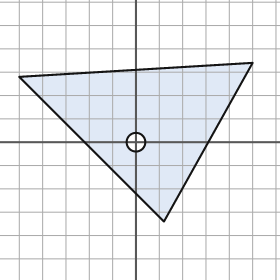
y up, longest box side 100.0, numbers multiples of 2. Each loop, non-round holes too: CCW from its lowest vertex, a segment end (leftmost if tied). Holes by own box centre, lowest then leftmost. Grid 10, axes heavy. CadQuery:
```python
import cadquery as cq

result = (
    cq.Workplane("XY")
    .moveTo(12.0, -34.0)
    .lineTo(50.0, 34.0)
    .lineTo(-50.0, 28.0)
    .close()
    .moveTo(0.0, 0.0)
    .circle(4.0)
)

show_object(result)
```